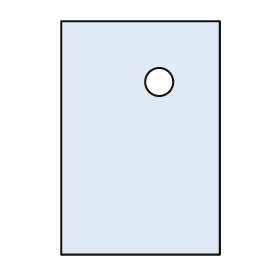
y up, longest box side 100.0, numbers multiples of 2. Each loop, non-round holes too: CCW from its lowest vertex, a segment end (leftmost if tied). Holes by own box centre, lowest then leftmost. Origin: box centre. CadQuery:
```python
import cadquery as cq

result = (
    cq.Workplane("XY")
    .moveTo(-34.0, -50.0)
    .lineTo(34.0, -50.0)
    .lineTo(34.0, 50.0)
    .lineTo(-34.0, 50.0)
    .close()
    .moveTo(8.0, 24.0)
    .circle(6.0)
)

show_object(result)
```